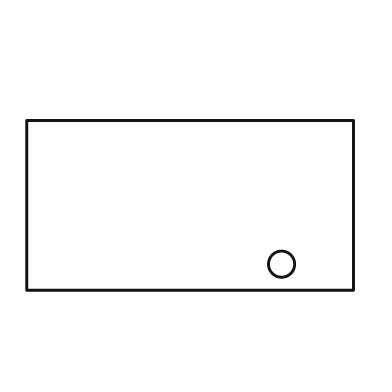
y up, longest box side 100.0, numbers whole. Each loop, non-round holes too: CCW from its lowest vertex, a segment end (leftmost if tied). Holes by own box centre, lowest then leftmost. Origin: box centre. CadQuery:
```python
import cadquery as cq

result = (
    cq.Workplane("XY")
    .moveTo(-50.0, -26.0)
    .lineTo(50.0, -26.0)
    .lineTo(50.0, 26.0)
    .lineTo(-50.0, 26.0)
    .close()
    .moveTo(28.0, -18.0)
    .circle(4.0)
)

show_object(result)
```